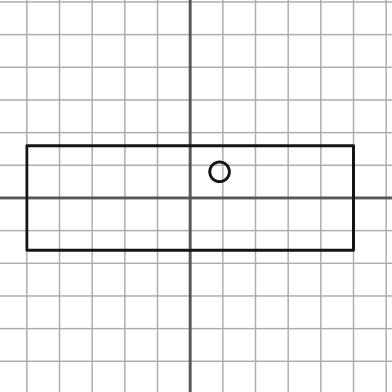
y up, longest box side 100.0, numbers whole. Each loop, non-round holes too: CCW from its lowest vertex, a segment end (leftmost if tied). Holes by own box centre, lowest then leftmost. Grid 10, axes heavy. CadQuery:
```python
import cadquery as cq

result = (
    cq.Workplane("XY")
    .moveTo(-50.0, -16.0)
    .lineTo(50.0, -16.0)
    .lineTo(50.0, 16.0)
    .lineTo(-50.0, 16.0)
    .close()
    .moveTo(9.0, 8.0)
    .circle(3.0)
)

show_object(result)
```